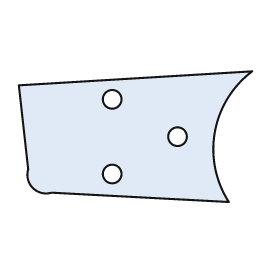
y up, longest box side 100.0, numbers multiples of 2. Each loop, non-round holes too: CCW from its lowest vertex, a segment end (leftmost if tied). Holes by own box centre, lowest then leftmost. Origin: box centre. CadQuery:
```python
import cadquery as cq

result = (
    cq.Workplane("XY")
    .moveTo(40.0, -28.0)
    .threePointArc((34.0, 2.0), (50.0, 28.0))
    .lineTo(-50.0, 22.0)
    .lineTo(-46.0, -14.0)
    .threePointArc((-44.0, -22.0), (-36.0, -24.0))
    .close()
    .moveTo(-10.0, -16.0)
    .circle(4.0)
    .moveTo(18.0, 0.0)
    .circle(4.0)
    .moveTo(-10.0, 16.0)
    .circle(4.0)
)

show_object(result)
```